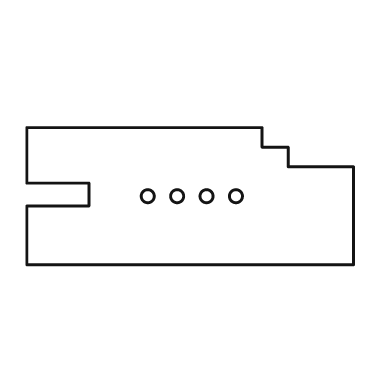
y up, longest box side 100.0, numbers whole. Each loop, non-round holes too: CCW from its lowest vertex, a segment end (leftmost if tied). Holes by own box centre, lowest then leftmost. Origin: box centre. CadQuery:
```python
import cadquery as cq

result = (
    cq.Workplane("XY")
    .moveTo(-50.0, -21.0)
    .lineTo(50.0, -21.0)
    .lineTo(50.0, 9.0)
    .lineTo(30.0, 9.0)
    .lineTo(30.0, 15.0)
    .lineTo(22.0, 15.0)
    .lineTo(22.0, 21.0)
    .lineTo(-50.0, 21.0)
    .lineTo(-50.0, 4.0)
    .lineTo(-31.0, 4.0)
    .lineTo(-31.0, -3.0)
    .lineTo(-50.0, -3.0)
    .close()
    .moveTo(-13.0, 0.0)
    .circle(2.0)
    .moveTo(-4.0, 0.0)
    .circle(2.0)
    .moveTo(5.0, 0.0)
    .circle(2.0)
    .moveTo(14.0, 0.0)
    .circle(2.0)
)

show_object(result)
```